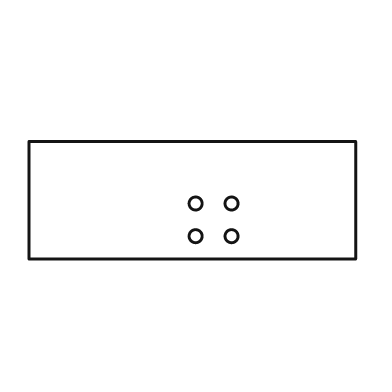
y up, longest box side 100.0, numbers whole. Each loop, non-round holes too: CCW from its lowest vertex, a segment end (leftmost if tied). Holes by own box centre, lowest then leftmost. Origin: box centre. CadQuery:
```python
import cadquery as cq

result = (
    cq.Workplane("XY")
    .moveTo(-50.0, -18.0)
    .lineTo(50.0, -18.0)
    .lineTo(50.0, 18.0)
    .lineTo(-50.0, 18.0)
    .close()
    .moveTo(1.0, -11.0)
    .circle(2.0)
    .moveTo(12.0, -11.0)
    .circle(2.0)
    .moveTo(1.0, -1.0)
    .circle(2.0)
    .moveTo(12.0, -1.0)
    .circle(2.0)
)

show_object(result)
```